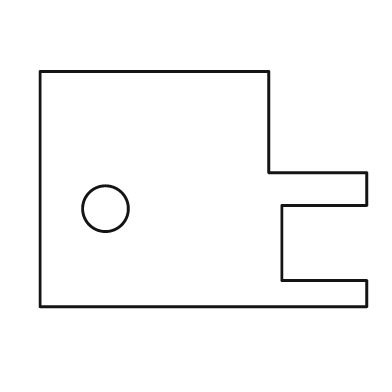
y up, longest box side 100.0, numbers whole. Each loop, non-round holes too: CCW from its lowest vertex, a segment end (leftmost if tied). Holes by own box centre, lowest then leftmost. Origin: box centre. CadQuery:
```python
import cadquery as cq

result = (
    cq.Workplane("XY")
    .moveTo(-50.0, -36.0)
    .lineTo(50.0, -36.0)
    .lineTo(50.0, -28.0)
    .lineTo(24.0, -28.0)
    .lineTo(24.0, -5.0)
    .lineTo(50.0, -5.0)
    .lineTo(50.0, 5.0)
    .lineTo(20.0, 5.0)
    .lineTo(20.0, 36.0)
    .lineTo(-50.0, 36.0)
    .close()
    .moveTo(-30.0, -6.0)
    .circle(7.0)
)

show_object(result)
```